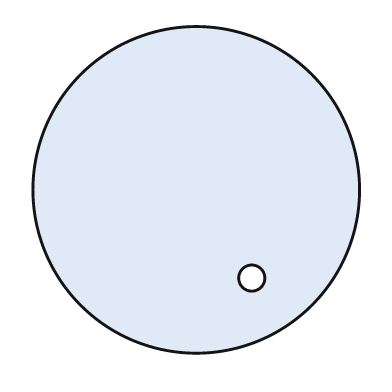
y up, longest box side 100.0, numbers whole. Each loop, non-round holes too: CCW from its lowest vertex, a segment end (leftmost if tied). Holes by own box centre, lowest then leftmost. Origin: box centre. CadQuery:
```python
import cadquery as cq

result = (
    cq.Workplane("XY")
    .moveTo(0.0, 0.0)
    .circle(50.0)
    .moveTo(17.0, -27.0)
    .circle(4.0)
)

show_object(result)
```